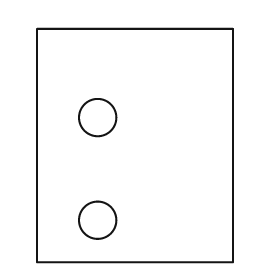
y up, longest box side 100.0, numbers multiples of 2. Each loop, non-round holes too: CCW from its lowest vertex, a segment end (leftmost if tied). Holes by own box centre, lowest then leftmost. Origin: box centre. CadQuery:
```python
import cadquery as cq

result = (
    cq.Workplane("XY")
    .moveTo(-42.0, -50.0)
    .lineTo(42.0, -50.0)
    .lineTo(42.0, 50.0)
    .lineTo(-42.0, 50.0)
    .close()
    .moveTo(-16.0, -32.0)
    .circle(8.0)
    .moveTo(-16.0, 12.0)
    .circle(8.0)
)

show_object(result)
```